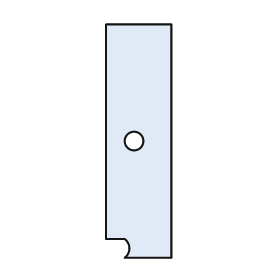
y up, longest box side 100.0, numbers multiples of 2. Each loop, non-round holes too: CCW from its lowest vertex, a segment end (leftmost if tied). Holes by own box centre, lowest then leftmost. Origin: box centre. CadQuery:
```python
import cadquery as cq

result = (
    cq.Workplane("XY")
    .moveTo(-6.0, -50.0)
    .lineTo(14.0, -50.0)
    .lineTo(14.0, 50.0)
    .lineTo(-14.0, 50.0)
    .lineTo(-14.0, -42.0)
    .lineTo(-6.0, -42.0)
    .threePointArc((-4.0, -46.0), (-6.0, -50.0))
    .close()
    .moveTo(-2.0, 0.0)
    .circle(4.0)
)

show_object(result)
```